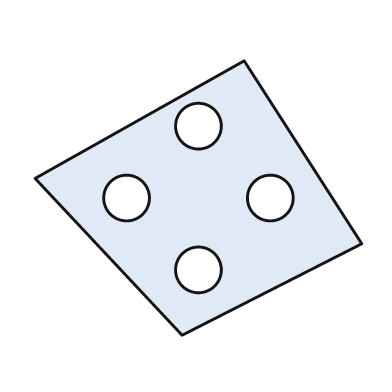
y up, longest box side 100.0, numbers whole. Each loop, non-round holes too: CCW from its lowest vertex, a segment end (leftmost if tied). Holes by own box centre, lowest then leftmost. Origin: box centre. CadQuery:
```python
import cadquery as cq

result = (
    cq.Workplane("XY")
    .moveTo(-5.0, -42.0)
    .lineTo(50.0, -14.0)
    .lineTo(14.0, 42.0)
    .lineTo(-50.0, 6.0)
    .close()
    .moveTo(0.0, -22.0)
    .circle(7.0)
    .moveTo(-22.0, 0.0)
    .circle(7.0)
    .moveTo(22.0, 0.0)
    .circle(7.0)
    .moveTo(0.0, 22.0)
    .circle(7.0)
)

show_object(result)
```